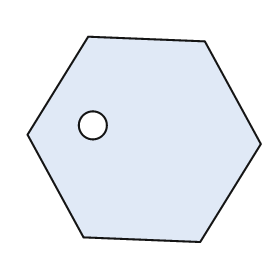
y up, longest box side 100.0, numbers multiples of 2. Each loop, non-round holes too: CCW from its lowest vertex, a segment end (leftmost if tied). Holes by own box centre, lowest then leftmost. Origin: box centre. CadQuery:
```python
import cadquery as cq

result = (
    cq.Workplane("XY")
    .moveTo(24.0, -44.0)
    .lineTo(50.0, -2.0)
    .lineTo(26.0, 42.0)
    .lineTo(-24.0, 44.0)
    .lineTo(-50.0, 2.0)
    .lineTo(-26.0, -42.0)
    .close()
    .moveTo(-22.0, 6.0)
    .circle(6.0)
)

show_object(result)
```